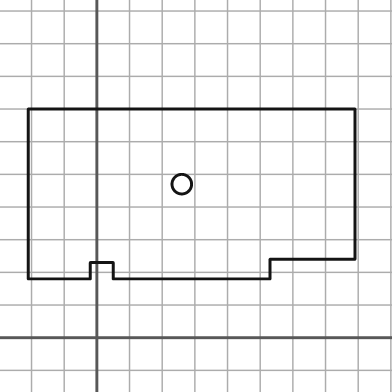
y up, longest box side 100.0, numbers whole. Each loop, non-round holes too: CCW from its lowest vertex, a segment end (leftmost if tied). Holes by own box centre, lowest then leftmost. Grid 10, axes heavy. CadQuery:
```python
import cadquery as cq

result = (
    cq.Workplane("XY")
    .moveTo(-21.0, 18.0)
    .lineTo(-2.0, 18.0)
    .lineTo(-2.0, 23.0)
    .lineTo(5.0, 23.0)
    .lineTo(5.0, 18.0)
    .lineTo(53.0, 18.0)
    .lineTo(53.0, 24.0)
    .lineTo(79.0, 24.0)
    .lineTo(79.0, 70.0)
    .lineTo(-21.0, 70.0)
    .close()
    .moveTo(26.0, 47.0)
    .circle(3.0)
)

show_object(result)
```